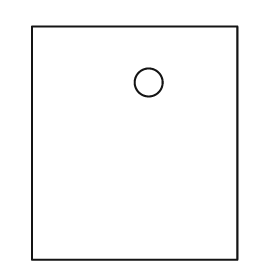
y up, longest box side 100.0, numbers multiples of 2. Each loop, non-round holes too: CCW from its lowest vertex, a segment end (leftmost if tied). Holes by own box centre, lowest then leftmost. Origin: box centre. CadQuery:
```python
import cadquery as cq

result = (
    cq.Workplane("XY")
    .moveTo(-44.0, -50.0)
    .lineTo(44.0, -50.0)
    .lineTo(44.0, 50.0)
    .lineTo(-44.0, 50.0)
    .close()
    .moveTo(6.0, 26.0)
    .circle(6.0)
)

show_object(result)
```